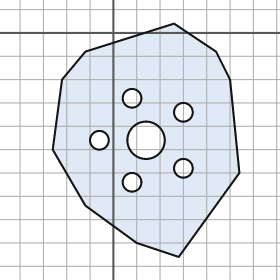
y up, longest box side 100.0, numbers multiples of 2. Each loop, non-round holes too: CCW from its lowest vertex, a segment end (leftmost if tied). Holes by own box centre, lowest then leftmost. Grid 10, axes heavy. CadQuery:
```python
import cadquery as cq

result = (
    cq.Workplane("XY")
    .moveTo(28.0, -96.0)
    .lineTo(54.0, -60.0)
    .lineTo(50.0, -20.0)
    .lineTo(44.0, -8.0)
    .lineTo(26.0, 4.0)
    .lineTo(-12.0, -8.0)
    .lineTo(-22.0, -20.0)
    .lineTo(-26.0, -50.0)
    .lineTo(-12.0, -74.0)
    .lineTo(10.0, -90.0)
    .close()
    .moveTo(8.0, -64.0)
    .circle(4.0)
    .moveTo(30.0, -58.0)
    .circle(4.0)
    .moveTo(-6.0, -46.0)
    .circle(4.0)
    .moveTo(14.0, -46.0)
    .circle(8.0)
    .moveTo(30.0, -34.0)
    .circle(4.0)
    .moveTo(8.0, -28.0)
    .circle(4.0)
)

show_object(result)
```